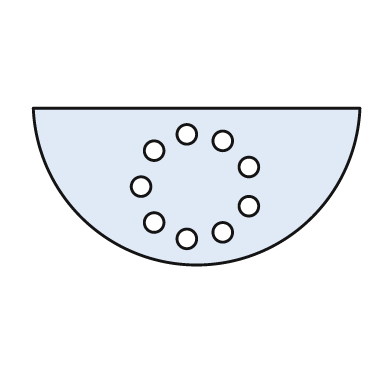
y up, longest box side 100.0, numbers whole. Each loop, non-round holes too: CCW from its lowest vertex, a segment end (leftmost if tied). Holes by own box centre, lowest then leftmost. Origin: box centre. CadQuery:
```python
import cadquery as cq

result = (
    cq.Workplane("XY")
    .moveTo(-50.0, 24.0)
    .threePointArc((0.0, -24.0), (50.0, 24.0))
    .close()
    .moveTo(-3.0, -16.0)
    .circle(3.0)
    .moveTo(8.0, -14.0)
    .circle(3.0)
    .moveTo(-13.0, -11.0)
    .circle(3.0)
    .moveTo(16.0, -6.0)
    .circle(3.0)
    .moveTo(-17.0, 0.0)
    .circle(3.0)
    .moveTo(16.0, 6.0)
    .circle(3.0)
    .moveTo(-13.0, 11.0)
    .circle(3.0)
    .moveTo(8.0, 14.0)
    .circle(3.0)
    .moveTo(-3.0, 16.0)
    .circle(3.0)
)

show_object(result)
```